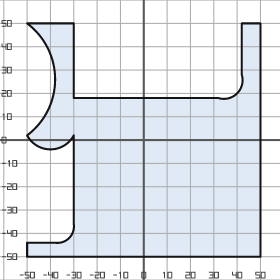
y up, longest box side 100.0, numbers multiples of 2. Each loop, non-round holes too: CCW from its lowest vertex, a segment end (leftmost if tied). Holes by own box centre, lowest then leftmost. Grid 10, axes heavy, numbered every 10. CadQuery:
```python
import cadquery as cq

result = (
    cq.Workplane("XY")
    .moveTo(-50.0, -50.0)
    .lineTo(50.0, -50.0)
    .lineTo(50.0, 50.0)
    .lineTo(42.0, 50.0)
    .lineTo(42.0, 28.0)
    .threePointArc((40.0, 20.0), (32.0, 18.0))
    .lineTo(-30.0, 18.0)
    .lineTo(-30.0, 50.0)
    .lineTo(-50.0, 50.0)
    .threePointArc((-38.0, 26.0), (-50.0, 2.0))
    .threePointArc((-40.0, -4.0), (-30.0, 2.0))
    .lineTo(-30.0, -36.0)
    .threePointArc((-32.0, -42.0), (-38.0, -44.0))
    .lineTo(-50.0, -44.0)
    .close()
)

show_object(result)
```